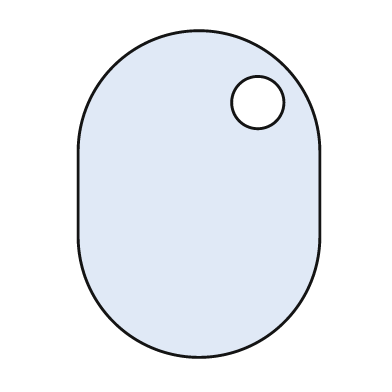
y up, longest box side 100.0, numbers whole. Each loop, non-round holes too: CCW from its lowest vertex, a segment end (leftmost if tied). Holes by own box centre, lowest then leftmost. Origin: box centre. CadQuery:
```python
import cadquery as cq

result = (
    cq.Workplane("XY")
    .moveTo(-37.0, -13.0)
    .threePointArc((0.0, -50.0), (37.0, -13.0))
    .lineTo(37.0, 13.0)
    .threePointArc((0.0, 50.0), (-37.0, 13.0))
    .close()
    .moveTo(18.0, 28.0)
    .circle(8.0)
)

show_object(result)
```